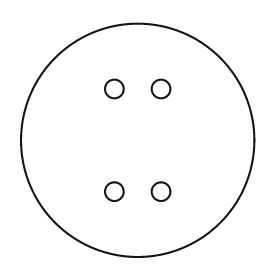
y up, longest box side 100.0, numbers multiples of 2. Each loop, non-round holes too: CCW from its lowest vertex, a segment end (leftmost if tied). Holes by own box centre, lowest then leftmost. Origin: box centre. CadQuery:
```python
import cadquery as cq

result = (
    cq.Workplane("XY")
    .moveTo(0.0, 0.0)
    .circle(50.0)
    .moveTo(-10.0, -22.0)
    .circle(4.0)
    .moveTo(10.0, -22.0)
    .circle(4.0)
    .moveTo(-10.0, 22.0)
    .circle(4.0)
    .moveTo(10.0, 22.0)
    .circle(4.0)
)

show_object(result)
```